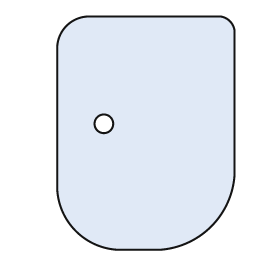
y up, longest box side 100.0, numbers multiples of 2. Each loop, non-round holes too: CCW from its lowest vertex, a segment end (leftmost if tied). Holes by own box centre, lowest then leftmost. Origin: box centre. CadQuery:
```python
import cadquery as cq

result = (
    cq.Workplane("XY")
    .moveTo(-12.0, -50.0)
    .lineTo(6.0, -50.0)
    .threePointArc((28.0, -40.0), (38.0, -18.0))
    .lineTo(38.0, 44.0)
    .threePointArc((36.0, 48.0), (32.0, 50.0))
    .lineTo(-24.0, 50.0)
    .threePointArc((-34.0, 46.0), (-38.0, 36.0))
    .lineTo(-38.0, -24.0)
    .threePointArc((-30.0, -42.0), (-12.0, -50.0))
    .close()
    .moveTo(-18.0, 4.0)
    .circle(4.0)
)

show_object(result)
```